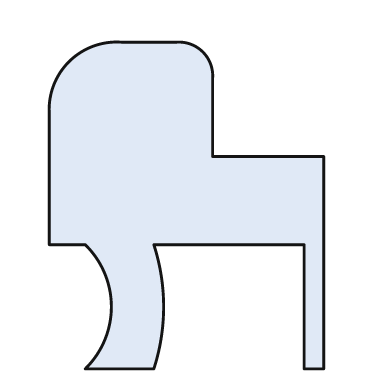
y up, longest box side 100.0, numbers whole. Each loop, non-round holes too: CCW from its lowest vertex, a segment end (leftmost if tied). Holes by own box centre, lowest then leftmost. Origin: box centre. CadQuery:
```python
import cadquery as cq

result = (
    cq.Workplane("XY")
    .moveTo(-31.0, -50.0)
    .lineTo(-10.0, -50.0)
    .threePointArc((-7.0, -31.0), (-10.0, -12.0))
    .lineTo(36.0, -12.0)
    .lineTo(36.0, -50.0)
    .lineTo(42.0, -50.0)
    .lineTo(42.0, 15.0)
    .lineTo(8.0, 15.0)
    .lineTo(8.0, 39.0)
    .threePointArc((5.0, 47.0), (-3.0, 50.0))
    .lineTo(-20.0, 50.0)
    .threePointArc((-36.0, 44.0), (-42.0, 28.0))
    .lineTo(-42.0, -12.0)
    .lineTo(-31.0, -12.0)
    .threePointArc((-23.0, -31.0), (-31.0, -50.0))
    .close()
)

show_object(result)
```